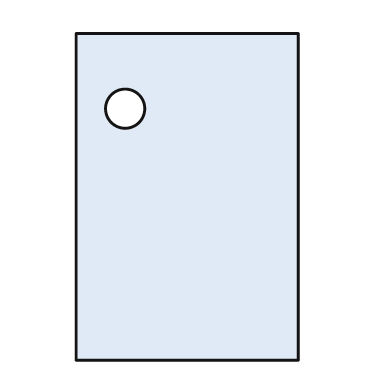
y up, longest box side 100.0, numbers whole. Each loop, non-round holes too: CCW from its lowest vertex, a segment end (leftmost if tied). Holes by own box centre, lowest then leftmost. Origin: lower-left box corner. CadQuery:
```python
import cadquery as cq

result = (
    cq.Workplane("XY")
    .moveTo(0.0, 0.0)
    .lineTo(68.0, 0.0)
    .lineTo(68.0, 100.0)
    .lineTo(0.0, 100.0)
    .close()
    .moveTo(15.0, 77.0)
    .circle(6.0)
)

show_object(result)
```